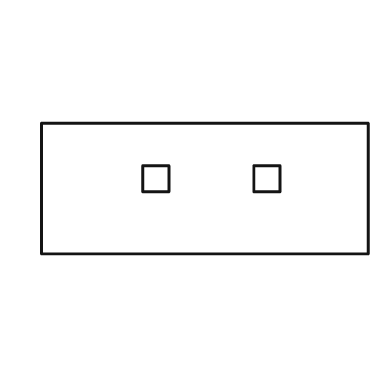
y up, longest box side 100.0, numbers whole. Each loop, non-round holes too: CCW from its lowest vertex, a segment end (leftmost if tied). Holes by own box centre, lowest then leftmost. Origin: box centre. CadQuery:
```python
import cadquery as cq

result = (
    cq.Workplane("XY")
    .moveTo(-50.0, -20.0)
    .lineTo(50.0, -20.0)
    .lineTo(50.0, 20.0)
    .lineTo(-50.0, 20.0)
    .close()
    .moveTo(-19.0, -1.0)
    .lineTo(-11.0, -1.0)
    .lineTo(-11.0, 7.0)
    .lineTo(-19.0, 7.0)
    .close()
    .moveTo(15.0, -1.0)
    .lineTo(23.0, -1.0)
    .lineTo(23.0, 7.0)
    .lineTo(15.0, 7.0)
    .close()
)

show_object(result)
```